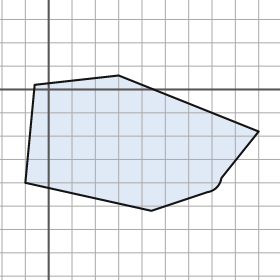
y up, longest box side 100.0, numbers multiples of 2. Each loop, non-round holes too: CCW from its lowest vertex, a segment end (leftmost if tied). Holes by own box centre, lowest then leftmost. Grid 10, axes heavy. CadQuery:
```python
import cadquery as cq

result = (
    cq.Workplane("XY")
    .moveTo(44.0, -52.0)
    .lineTo(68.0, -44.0)
    .threePointArc((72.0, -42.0), (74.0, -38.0))
    .lineTo(90.0, -18.0)
    .lineTo(30.0, 6.0)
    .lineTo(-6.0, 2.0)
    .lineTo(-10.0, -40.0)
    .close()
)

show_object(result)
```